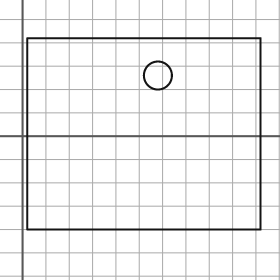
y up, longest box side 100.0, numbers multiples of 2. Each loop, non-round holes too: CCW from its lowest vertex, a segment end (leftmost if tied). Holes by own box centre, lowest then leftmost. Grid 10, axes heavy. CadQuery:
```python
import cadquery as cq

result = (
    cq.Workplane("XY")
    .moveTo(2.0, -40.0)
    .lineTo(102.0, -40.0)
    .lineTo(102.0, 42.0)
    .lineTo(2.0, 42.0)
    .close()
    .moveTo(58.0, 26.0)
    .circle(6.0)
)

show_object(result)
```